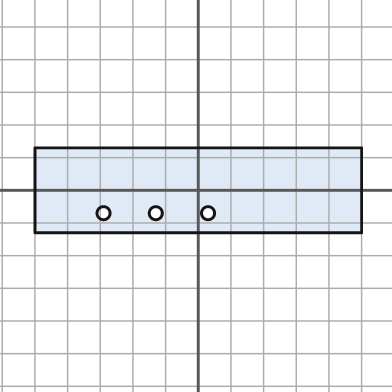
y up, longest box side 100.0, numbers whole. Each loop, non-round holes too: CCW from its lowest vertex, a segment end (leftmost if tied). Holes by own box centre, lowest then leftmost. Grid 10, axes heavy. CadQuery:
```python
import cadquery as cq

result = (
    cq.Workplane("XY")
    .moveTo(-50.0, -13.0)
    .lineTo(50.0, -13.0)
    .lineTo(50.0, 13.0)
    .lineTo(-50.0, 13.0)
    .close()
    .moveTo(-29.0, -7.0)
    .circle(2.0)
    .moveTo(-13.0, -7.0)
    .circle(2.0)
    .moveTo(3.0, -7.0)
    .circle(2.0)
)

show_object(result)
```